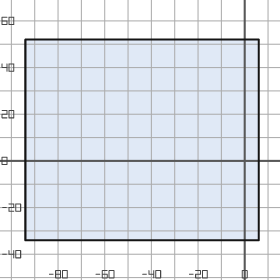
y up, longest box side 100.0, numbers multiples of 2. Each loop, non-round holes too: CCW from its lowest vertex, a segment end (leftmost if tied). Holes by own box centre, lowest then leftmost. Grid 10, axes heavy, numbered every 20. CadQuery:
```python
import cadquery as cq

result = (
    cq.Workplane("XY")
    .moveTo(-94.0, -34.0)
    .lineTo(6.0, -34.0)
    .lineTo(6.0, 52.0)
    .lineTo(-94.0, 52.0)
    .close()
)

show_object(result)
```